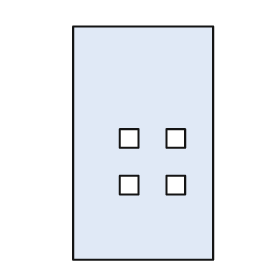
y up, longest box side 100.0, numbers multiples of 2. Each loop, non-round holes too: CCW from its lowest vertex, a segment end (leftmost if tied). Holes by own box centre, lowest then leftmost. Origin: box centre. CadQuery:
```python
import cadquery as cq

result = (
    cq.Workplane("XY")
    .moveTo(-30.0, -50.0)
    .lineTo(30.0, -50.0)
    .lineTo(30.0, 50.0)
    .lineTo(-30.0, 50.0)
    .close()
    .moveTo(-10.0, -22.0)
    .lineTo(-2.0, -22.0)
    .lineTo(-2.0, -14.0)
    .lineTo(-10.0, -14.0)
    .close()
    .moveTo(10.0, -22.0)
    .lineTo(18.0, -22.0)
    .lineTo(18.0, -14.0)
    .lineTo(10.0, -14.0)
    .close()
    .moveTo(-10.0, -2.0)
    .lineTo(-2.0, -2.0)
    .lineTo(-2.0, 6.0)
    .lineTo(-10.0, 6.0)
    .close()
    .moveTo(10.0, -2.0)
    .lineTo(18.0, -2.0)
    .lineTo(18.0, 6.0)
    .lineTo(10.0, 6.0)
    .close()
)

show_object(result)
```